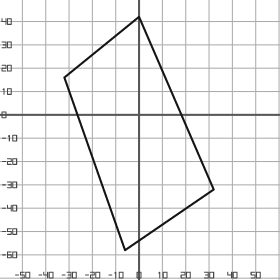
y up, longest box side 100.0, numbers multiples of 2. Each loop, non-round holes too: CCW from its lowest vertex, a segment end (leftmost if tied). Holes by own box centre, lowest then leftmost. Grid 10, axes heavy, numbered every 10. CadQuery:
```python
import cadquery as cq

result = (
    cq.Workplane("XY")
    .moveTo(-6.0, -58.0)
    .lineTo(32.0, -32.0)
    .lineTo(0.0, 42.0)
    .lineTo(-32.0, 16.0)
    .close()
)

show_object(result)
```